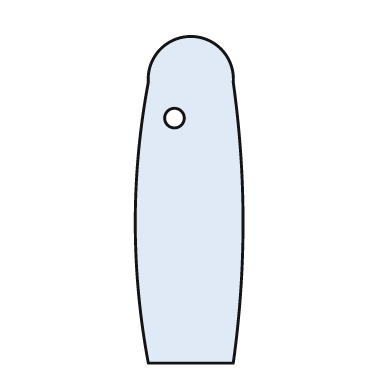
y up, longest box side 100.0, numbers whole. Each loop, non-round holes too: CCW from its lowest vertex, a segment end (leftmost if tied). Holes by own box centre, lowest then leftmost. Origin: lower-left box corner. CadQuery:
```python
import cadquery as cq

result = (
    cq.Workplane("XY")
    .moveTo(4.0, 0.0)
    .lineTo(30.0, 0.0)
    .threePointArc((33.0, 43.0), (30.0, 86.0))
    .threePointArc((17.0, 100.0), (4.0, 86.0))
    .threePointArc((0.0, 43.0), (4.0, 0.0))
    .close()
    .moveTo(12.0, 75.0)
    .circle(3.0)
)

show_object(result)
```